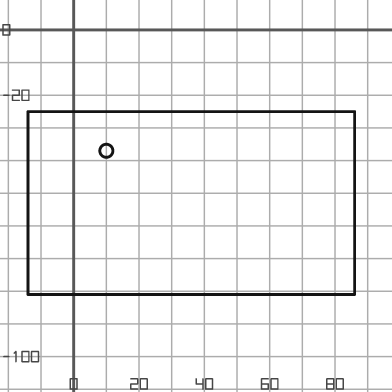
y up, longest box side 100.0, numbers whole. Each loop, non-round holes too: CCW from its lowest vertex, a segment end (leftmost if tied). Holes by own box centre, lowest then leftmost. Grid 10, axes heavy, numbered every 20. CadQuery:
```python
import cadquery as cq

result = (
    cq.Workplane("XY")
    .moveTo(-14.0, -81.0)
    .lineTo(86.0, -81.0)
    .lineTo(86.0, -25.0)
    .lineTo(-14.0, -25.0)
    .close()
    .moveTo(10.0, -37.0)
    .circle(2.0)
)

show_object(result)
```